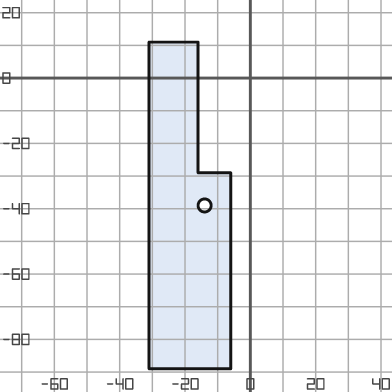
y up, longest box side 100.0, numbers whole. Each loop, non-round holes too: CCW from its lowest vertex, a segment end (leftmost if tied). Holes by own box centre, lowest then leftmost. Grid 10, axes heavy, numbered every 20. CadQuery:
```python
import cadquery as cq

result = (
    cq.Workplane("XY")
    .moveTo(-31.0, -89.0)
    .lineTo(-6.0, -89.0)
    .lineTo(-6.0, -29.0)
    .lineTo(-16.0, -29.0)
    .lineTo(-16.0, 11.0)
    .lineTo(-31.0, 11.0)
    .close()
    .moveTo(-14.0, -39.0)
    .circle(2.0)
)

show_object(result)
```